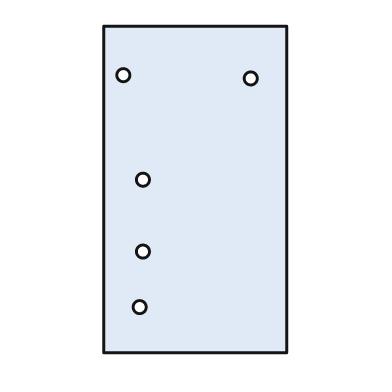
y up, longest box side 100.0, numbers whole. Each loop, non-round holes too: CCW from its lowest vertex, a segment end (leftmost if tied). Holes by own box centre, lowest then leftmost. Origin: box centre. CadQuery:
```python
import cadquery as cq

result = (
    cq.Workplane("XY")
    .moveTo(-28.0, -50.0)
    .lineTo(28.0, -50.0)
    .lineTo(28.0, 50.0)
    .lineTo(-28.0, 50.0)
    .close()
    .moveTo(-17.0, -36.0)
    .circle(2.0)
    .moveTo(-16.0, -19.0)
    .circle(2.0)
    .moveTo(-16.0, 3.0)
    .circle(2.0)
    .moveTo(17.0, 34.0)
    .circle(2.0)
    .moveTo(-22.0, 35.0)
    .circle(2.0)
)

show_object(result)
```